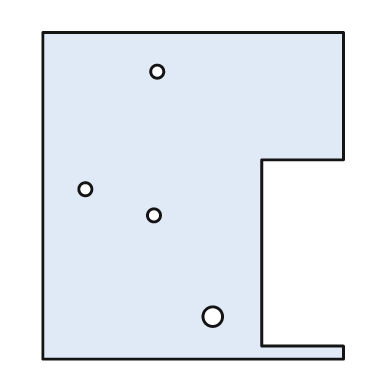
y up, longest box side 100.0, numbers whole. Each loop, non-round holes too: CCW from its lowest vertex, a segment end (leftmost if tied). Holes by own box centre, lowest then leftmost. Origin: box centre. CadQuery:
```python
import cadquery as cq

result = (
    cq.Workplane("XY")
    .moveTo(-46.0, -50.0)
    .lineTo(46.0, -50.0)
    .lineTo(46.0, -46.0)
    .lineTo(21.0, -46.0)
    .lineTo(21.0, 11.0)
    .lineTo(46.0, 11.0)
    .lineTo(46.0, 50.0)
    .lineTo(-46.0, 50.0)
    .close()
    .moveTo(6.0, -37.0)
    .circle(3.0)
    .moveTo(-12.0, -6.0)
    .circle(2.0)
    .moveTo(-33.0, 2.0)
    .circle(2.0)
    .moveTo(-11.0, 38.0)
    .circle(2.0)
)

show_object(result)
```